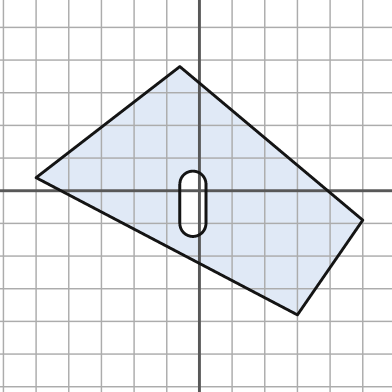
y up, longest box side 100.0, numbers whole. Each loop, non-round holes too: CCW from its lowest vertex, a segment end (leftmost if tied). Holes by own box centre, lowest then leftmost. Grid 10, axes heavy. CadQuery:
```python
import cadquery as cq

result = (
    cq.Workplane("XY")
    .moveTo(30.0, -38.0)
    .lineTo(50.0, -9.0)
    .lineTo(-6.0, 38.0)
    .lineTo(-50.0, 4.0)
    .close()
    .moveTo(-6.0, -10.0)
    .threePointArc((-2.0, -14.0), (2.0, -10.0))
    .lineTo(2.0, 2.0)
    .threePointArc((-2.0, 6.0), (-6.0, 2.0))
    .close()
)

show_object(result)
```